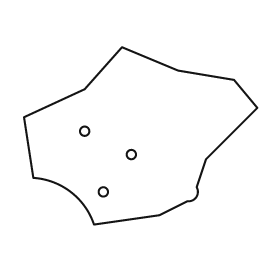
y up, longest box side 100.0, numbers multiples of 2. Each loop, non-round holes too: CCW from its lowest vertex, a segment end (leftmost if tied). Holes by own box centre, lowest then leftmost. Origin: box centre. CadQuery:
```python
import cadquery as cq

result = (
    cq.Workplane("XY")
    .moveTo(-20.0, -38.0)
    .lineTo(8.0, -34.0)
    .lineTo(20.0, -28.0)
    .threePointArc((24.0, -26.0), (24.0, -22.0))
    .lineTo(28.0, -10.0)
    .lineTo(50.0, 12.0)
    .lineTo(40.0, 24.0)
    .lineTo(16.0, 28.0)
    .lineTo(-8.0, 38.0)
    .lineTo(-24.0, 20.0)
    .lineTo(-50.0, 8.0)
    .lineTo(-46.0, -18.0)
    .threePointArc((-30.0, -24.0), (-20.0, -38.0))
    .close()
    .moveTo(-16.0, -24.0)
    .circle(2.0)
    .moveTo(-4.0, -8.0)
    .circle(2.0)
    .moveTo(-24.0, 2.0)
    .circle(2.0)
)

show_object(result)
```